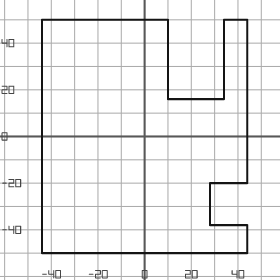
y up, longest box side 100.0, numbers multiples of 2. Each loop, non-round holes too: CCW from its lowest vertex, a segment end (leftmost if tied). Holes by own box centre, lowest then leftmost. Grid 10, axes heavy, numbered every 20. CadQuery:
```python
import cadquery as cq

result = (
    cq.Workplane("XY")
    .moveTo(-44.0, -50.0)
    .lineTo(44.0, -50.0)
    .lineTo(44.0, -38.0)
    .lineTo(28.0, -38.0)
    .lineTo(28.0, -20.0)
    .lineTo(44.0, -20.0)
    .lineTo(44.0, 50.0)
    .lineTo(34.0, 50.0)
    .lineTo(34.0, 16.0)
    .lineTo(10.0, 16.0)
    .lineTo(10.0, 50.0)
    .lineTo(-44.0, 50.0)
    .close()
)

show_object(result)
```